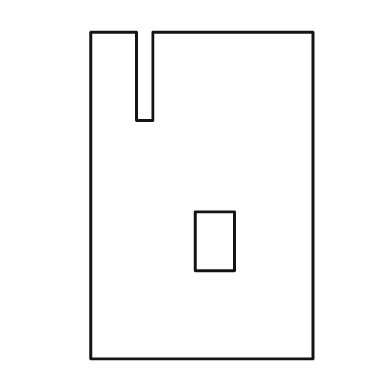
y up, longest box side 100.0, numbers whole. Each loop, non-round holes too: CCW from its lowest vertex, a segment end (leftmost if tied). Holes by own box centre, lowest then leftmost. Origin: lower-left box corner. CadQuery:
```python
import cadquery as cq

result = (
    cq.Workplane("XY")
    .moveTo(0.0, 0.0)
    .lineTo(68.0, 0.0)
    .lineTo(68.0, 100.0)
    .lineTo(19.0, 100.0)
    .lineTo(19.0, 73.0)
    .lineTo(14.0, 73.0)
    .lineTo(14.0, 100.0)
    .lineTo(0.0, 100.0)
    .close()
    .moveTo(32.0, 27.0)
    .lineTo(44.0, 27.0)
    .lineTo(44.0, 45.0)
    .lineTo(32.0, 45.0)
    .close()
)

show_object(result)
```